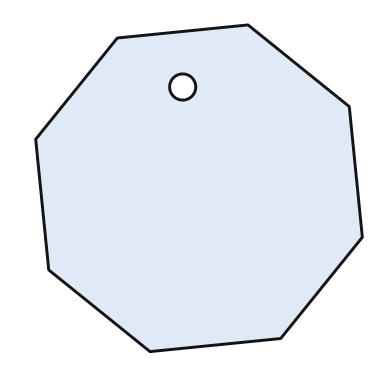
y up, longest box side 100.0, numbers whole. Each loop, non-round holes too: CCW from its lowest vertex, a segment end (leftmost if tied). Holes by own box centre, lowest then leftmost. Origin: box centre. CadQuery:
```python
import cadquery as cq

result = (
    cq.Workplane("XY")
    .moveTo(-15.0, -50.0)
    .lineTo(25.0, -46.0)
    .lineTo(50.0, -15.0)
    .lineTo(46.0, 25.0)
    .lineTo(15.0, 50.0)
    .lineTo(-25.0, 46.0)
    .lineTo(-50.0, 15.0)
    .lineTo(-46.0, -25.0)
    .close()
    .moveTo(-5.0, 31.0)
    .circle(4.0)
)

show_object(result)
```